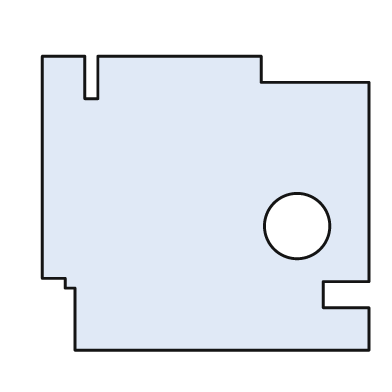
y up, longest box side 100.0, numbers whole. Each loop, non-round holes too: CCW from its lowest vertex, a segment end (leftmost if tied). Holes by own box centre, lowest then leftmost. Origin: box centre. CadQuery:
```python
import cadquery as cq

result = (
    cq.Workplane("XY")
    .moveTo(-40.0, -45.0)
    .lineTo(50.0, -45.0)
    .lineTo(50.0, -32.0)
    .lineTo(36.0, -32.0)
    .lineTo(36.0, -24.0)
    .lineTo(50.0, -24.0)
    .lineTo(50.0, 37.0)
    .lineTo(17.0, 37.0)
    .lineTo(17.0, 45.0)
    .lineTo(-33.0, 45.0)
    .lineTo(-33.0, 32.0)
    .lineTo(-37.0, 32.0)
    .lineTo(-37.0, 45.0)
    .lineTo(-50.0, 45.0)
    .lineTo(-50.0, -23.0)
    .lineTo(-43.0, -23.0)
    .lineTo(-43.0, -26.0)
    .lineTo(-40.0, -26.0)
    .close()
    .moveTo(28.0, -7.0)
    .circle(10.0)
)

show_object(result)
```